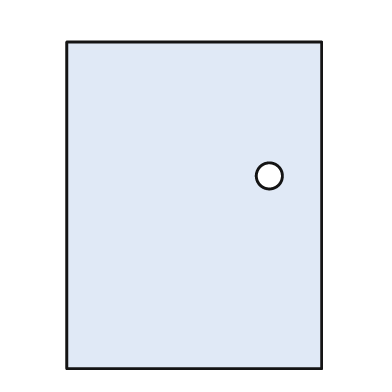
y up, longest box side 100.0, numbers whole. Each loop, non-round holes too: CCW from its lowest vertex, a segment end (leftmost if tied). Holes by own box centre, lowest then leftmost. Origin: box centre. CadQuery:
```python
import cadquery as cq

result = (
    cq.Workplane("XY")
    .moveTo(-39.0, -50.0)
    .lineTo(39.0, -50.0)
    .lineTo(39.0, 50.0)
    .lineTo(-39.0, 50.0)
    .close()
    .moveTo(23.0, 9.0)
    .circle(4.0)
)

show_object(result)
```